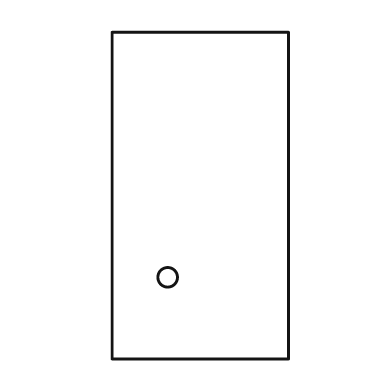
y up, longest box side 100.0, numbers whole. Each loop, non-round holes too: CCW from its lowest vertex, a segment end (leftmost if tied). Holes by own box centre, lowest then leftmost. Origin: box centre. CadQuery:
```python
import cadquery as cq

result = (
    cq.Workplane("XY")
    .moveTo(-27.0, -50.0)
    .lineTo(27.0, -50.0)
    .lineTo(27.0, 50.0)
    .lineTo(-27.0, 50.0)
    .close()
    .moveTo(-10.0, -25.0)
    .circle(3.0)
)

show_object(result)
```